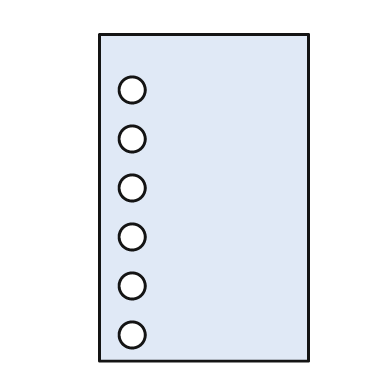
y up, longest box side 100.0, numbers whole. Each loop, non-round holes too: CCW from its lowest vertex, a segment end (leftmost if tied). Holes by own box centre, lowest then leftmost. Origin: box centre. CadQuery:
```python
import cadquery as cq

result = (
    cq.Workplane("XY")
    .moveTo(-32.0, -50.0)
    .lineTo(32.0, -50.0)
    .lineTo(32.0, 50.0)
    .lineTo(-32.0, 50.0)
    .close()
    .moveTo(-22.0, -42.0)
    .circle(4.0)
    .moveTo(-22.0, -27.0)
    .circle(4.0)
    .moveTo(-22.0, -12.0)
    .circle(4.0)
    .moveTo(-22.0, 3.0)
    .circle(4.0)
    .moveTo(-22.0, 18.0)
    .circle(4.0)
    .moveTo(-22.0, 33.0)
    .circle(4.0)
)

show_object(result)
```